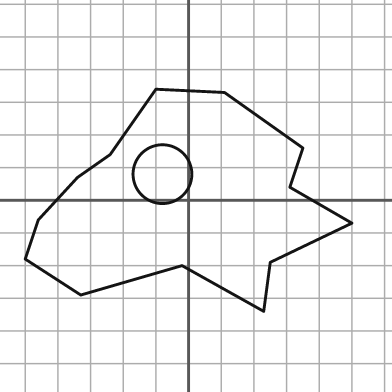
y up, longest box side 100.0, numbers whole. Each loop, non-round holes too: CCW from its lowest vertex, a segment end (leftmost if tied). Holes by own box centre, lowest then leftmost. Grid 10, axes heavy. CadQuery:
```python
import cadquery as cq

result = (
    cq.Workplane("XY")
    .moveTo(23.0, -34.0)
    .lineTo(25.0, -19.0)
    .lineTo(50.0, -7.0)
    .lineTo(31.0, 4.0)
    .lineTo(35.0, 16.0)
    .lineTo(11.0, 33.0)
    .lineTo(-10.0, 34.0)
    .lineTo(-24.0, 14.0)
    .lineTo(-34.0, 7.0)
    .lineTo(-46.0, -6.0)
    .lineTo(-50.0, -18.0)
    .lineTo(-33.0, -29.0)
    .lineTo(-2.0, -20.0)
    .close()
    .moveTo(-8.0, 8.0)
    .circle(9.0)
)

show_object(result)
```